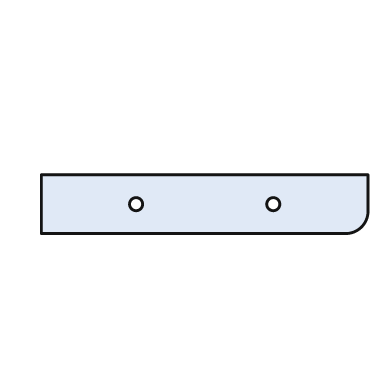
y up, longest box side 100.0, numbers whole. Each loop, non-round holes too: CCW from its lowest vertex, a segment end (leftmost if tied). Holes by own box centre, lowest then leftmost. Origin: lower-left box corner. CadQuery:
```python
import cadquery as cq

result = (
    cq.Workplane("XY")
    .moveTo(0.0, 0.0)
    .lineTo(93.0, 0.0)
    .threePointArc((98.0, 2.0), (100.0, 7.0))
    .lineTo(100.0, 18.0)
    .lineTo(0.0, 18.0)
    .close()
    .moveTo(29.0, 9.0)
    .circle(2.0)
    .moveTo(71.0, 9.0)
    .circle(2.0)
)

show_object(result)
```